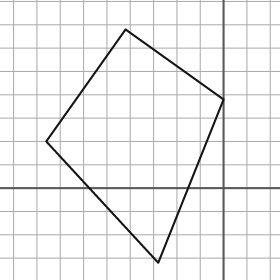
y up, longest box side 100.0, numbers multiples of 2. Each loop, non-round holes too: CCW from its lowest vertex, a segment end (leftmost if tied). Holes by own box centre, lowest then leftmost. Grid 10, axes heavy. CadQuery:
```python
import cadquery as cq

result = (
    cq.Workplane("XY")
    .moveTo(-28.0, -32.0)
    .lineTo(0.0, 38.0)
    .lineTo(-42.0, 68.0)
    .lineTo(-76.0, 20.0)
    .close()
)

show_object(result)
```